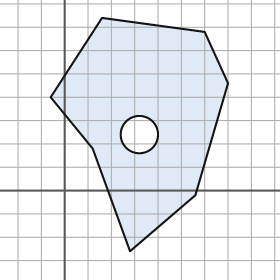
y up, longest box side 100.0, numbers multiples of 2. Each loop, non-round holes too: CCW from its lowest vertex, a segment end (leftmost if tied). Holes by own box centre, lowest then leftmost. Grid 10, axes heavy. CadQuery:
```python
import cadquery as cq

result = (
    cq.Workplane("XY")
    .moveTo(28.0, -26.0)
    .lineTo(56.0, -2.0)
    .lineTo(70.0, 46.0)
    .lineTo(60.0, 68.0)
    .lineTo(16.0, 74.0)
    .lineTo(-6.0, 40.0)
    .lineTo(12.0, 18.0)
    .close()
    .moveTo(32.0, 24.0)
    .circle(8.0)
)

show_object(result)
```